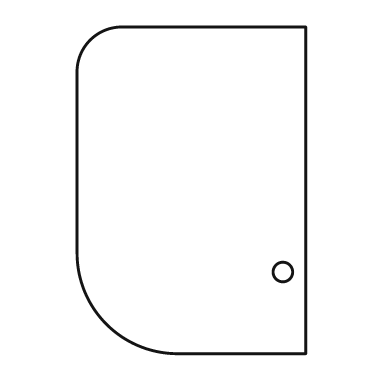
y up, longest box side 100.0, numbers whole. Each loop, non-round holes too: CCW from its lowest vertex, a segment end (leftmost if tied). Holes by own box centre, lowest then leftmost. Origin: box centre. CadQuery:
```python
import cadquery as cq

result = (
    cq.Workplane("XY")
    .moveTo(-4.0, -50.0)
    .lineTo(35.0, -50.0)
    .lineTo(35.0, 50.0)
    .lineTo(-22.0, 50.0)
    .threePointArc((-31.0, 46.0), (-35.0, 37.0))
    .lineTo(-35.0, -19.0)
    .threePointArc((-26.0, -41.0), (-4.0, -50.0))
    .close()
    .moveTo(28.0, -25.0)
    .circle(3.0)
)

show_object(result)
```